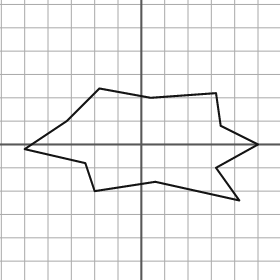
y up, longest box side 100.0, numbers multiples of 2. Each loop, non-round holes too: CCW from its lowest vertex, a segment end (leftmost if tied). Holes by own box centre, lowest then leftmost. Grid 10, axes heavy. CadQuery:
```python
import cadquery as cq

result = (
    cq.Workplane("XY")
    .moveTo(42.0, -24.0)
    .lineTo(32.0, -10.0)
    .lineTo(50.0, 0.0)
    .lineTo(34.0, 8.0)
    .lineTo(32.0, 22.0)
    .lineTo(4.0, 20.0)
    .lineTo(-18.0, 24.0)
    .lineTo(-32.0, 10.0)
    .lineTo(-50.0, -2.0)
    .lineTo(-24.0, -8.0)
    .lineTo(-20.0, -20.0)
    .lineTo(6.0, -16.0)
    .close()
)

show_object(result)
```